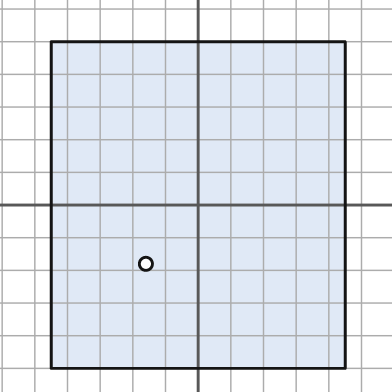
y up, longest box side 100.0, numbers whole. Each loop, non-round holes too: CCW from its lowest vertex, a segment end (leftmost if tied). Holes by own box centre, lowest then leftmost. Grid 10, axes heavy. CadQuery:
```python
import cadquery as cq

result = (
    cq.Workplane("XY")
    .moveTo(-45.0, -50.0)
    .lineTo(45.0, -50.0)
    .lineTo(45.0, 50.0)
    .lineTo(-45.0, 50.0)
    .close()
    .moveTo(-16.0, -18.0)
    .circle(2.0)
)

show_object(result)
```